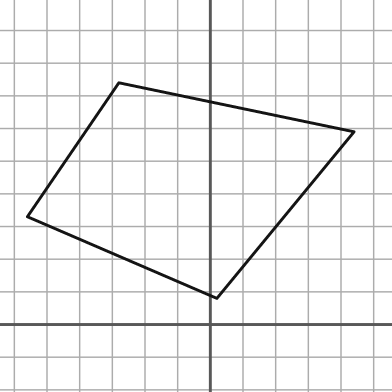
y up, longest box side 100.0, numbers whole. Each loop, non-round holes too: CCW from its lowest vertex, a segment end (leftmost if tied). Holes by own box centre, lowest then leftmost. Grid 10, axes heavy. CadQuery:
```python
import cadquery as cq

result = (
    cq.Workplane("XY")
    .moveTo(2.0, 8.0)
    .lineTo(44.0, 59.0)
    .lineTo(-28.0, 74.0)
    .lineTo(-56.0, 33.0)
    .close()
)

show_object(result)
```